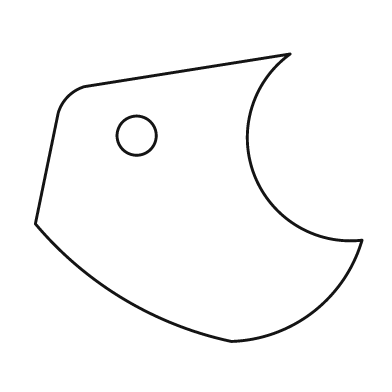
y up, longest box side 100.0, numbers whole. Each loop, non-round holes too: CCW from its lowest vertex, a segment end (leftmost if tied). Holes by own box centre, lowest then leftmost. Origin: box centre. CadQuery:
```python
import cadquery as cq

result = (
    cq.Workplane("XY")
    .moveTo(10.0, -44.0)
    .threePointArc((35.0, -35.0), (50.0, -13.0))
    .threePointArc((17.0, 7.0), (28.0, 44.0))
    .lineTo(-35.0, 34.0)
    .threePointArc((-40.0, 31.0), (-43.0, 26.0))
    .lineTo(-50.0, -8.0)
    .threePointArc((-23.0, -31.0), (10.0, -44.0))
    .close()
    .moveTo(-19.0, 19.0)
    .circle(6.0)
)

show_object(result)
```